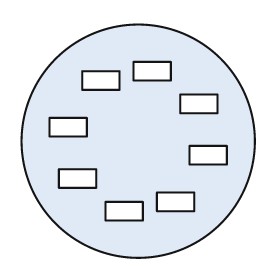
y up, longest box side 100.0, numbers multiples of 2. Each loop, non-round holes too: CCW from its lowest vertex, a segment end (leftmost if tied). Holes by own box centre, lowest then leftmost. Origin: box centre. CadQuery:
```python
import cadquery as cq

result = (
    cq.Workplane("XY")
    .moveTo(0.0, 0.0)
    .circle(50.0)
    .moveTo(-14.0, -34.0)
    .lineTo(2.0, -34.0)
    .lineTo(2.0, -26.0)
    .lineTo(-14.0, -26.0)
    .close()
    .moveTo(8.0, -30.0)
    .lineTo(24.0, -30.0)
    .lineTo(24.0, -22.0)
    .lineTo(8.0, -22.0)
    .close()
    .moveTo(-34.0, -20.0)
    .lineTo(-18.0, -20.0)
    .lineTo(-18.0, -12.0)
    .lineTo(-34.0, -12.0)
    .close()
    .moveTo(22.0, -10.0)
    .lineTo(38.0, -10.0)
    .lineTo(38.0, -2.0)
    .lineTo(22.0, -2.0)
    .close()
    .moveTo(-38.0, 2.0)
    .lineTo(-22.0, 2.0)
    .lineTo(-22.0, 10.0)
    .lineTo(-38.0, 10.0)
    .close()
    .moveTo(18.0, 12.0)
    .lineTo(34.0, 12.0)
    .lineTo(34.0, 20.0)
    .lineTo(18.0, 20.0)
    .close()
    .moveTo(-24.0, 22.0)
    .lineTo(-8.0, 22.0)
    .lineTo(-8.0, 30.0)
    .lineTo(-24.0, 30.0)
    .close()
    .moveTo(-2.0, 26.0)
    .lineTo(14.0, 26.0)
    .lineTo(14.0, 34.0)
    .lineTo(-2.0, 34.0)
    .close()
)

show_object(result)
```